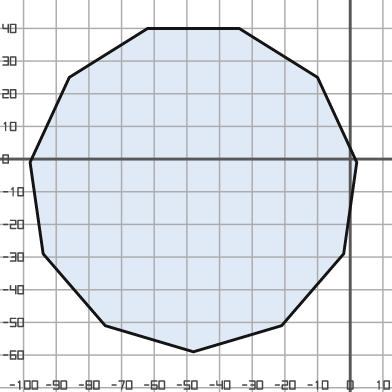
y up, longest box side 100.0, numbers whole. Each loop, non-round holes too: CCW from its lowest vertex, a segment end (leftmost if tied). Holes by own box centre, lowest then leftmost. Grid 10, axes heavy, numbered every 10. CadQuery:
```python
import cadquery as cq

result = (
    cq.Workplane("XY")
    .moveTo(-48.0, -59.0)
    .lineTo(-21.0, -51.0)
    .lineTo(-2.0, -29.0)
    .lineTo(2.0, -1.0)
    .lineTo(-10.0, 25.0)
    .lineTo(-34.0, 40.0)
    .lineTo(-62.0, 40.0)
    .lineTo(-86.0, 25.0)
    .lineTo(-98.0, -1.0)
    .lineTo(-94.0, -29.0)
    .lineTo(-75.0, -51.0)
    .close()
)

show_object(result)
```